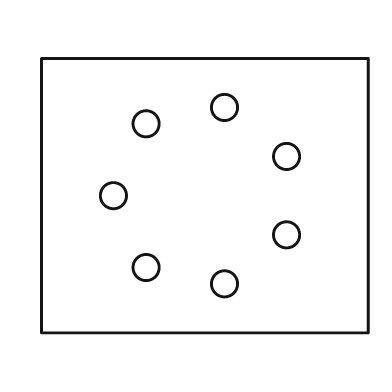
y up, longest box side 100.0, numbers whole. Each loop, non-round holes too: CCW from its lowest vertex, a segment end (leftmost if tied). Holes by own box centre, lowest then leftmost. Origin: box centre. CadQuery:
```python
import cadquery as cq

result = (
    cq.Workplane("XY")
    .moveTo(-50.0, -42.0)
    .lineTo(50.0, -42.0)
    .lineTo(50.0, 42.0)
    .lineTo(-50.0, 42.0)
    .close()
    .moveTo(6.0, -27.0)
    .circle(4.0)
    .moveTo(-18.0, -22.0)
    .circle(4.0)
    .moveTo(25.0, -12.0)
    .circle(4.0)
    .moveTo(-28.0, 0.0)
    .circle(4.0)
    .moveTo(25.0, 12.0)
    .circle(4.0)
    .moveTo(-18.0, 22.0)
    .circle(4.0)
    .moveTo(6.0, 27.0)
    .circle(4.0)
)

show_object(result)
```